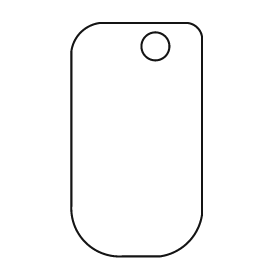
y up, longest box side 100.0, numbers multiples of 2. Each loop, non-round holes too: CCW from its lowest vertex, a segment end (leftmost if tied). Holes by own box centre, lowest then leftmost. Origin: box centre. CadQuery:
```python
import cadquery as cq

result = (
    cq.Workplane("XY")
    .moveTo(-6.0, -50.0)
    .lineTo(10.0, -50.0)
    .threePointArc((22.0, -44.0), (28.0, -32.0))
    .lineTo(28.0, 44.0)
    .threePointArc((26.0, 48.0), (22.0, 50.0))
    .lineTo(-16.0, 50.0)
    .threePointArc((-24.0, 46.0), (-28.0, 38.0))
    .lineTo(-28.0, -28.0)
    .threePointArc((-22.0, -44.0), (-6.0, -50.0))
    .close()
    .moveTo(8.0, 40.0)
    .circle(6.0)
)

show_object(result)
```